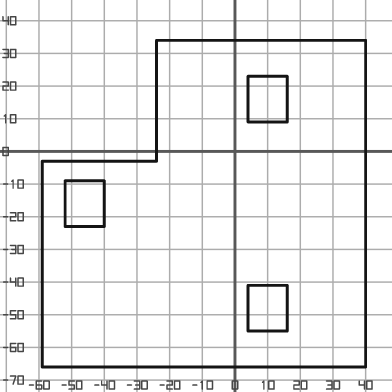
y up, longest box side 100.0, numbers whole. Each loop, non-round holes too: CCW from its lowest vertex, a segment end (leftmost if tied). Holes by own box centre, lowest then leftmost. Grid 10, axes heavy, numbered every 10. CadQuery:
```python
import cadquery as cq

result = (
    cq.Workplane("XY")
    .moveTo(-59.0, -66.0)
    .lineTo(40.0, -66.0)
    .lineTo(40.0, 34.0)
    .lineTo(-24.0, 34.0)
    .lineTo(-24.0, -3.0)
    .lineTo(-59.0, -3.0)
    .close()
    .moveTo(4.0, -55.0)
    .lineTo(16.0, -55.0)
    .lineTo(16.0, -41.0)
    .lineTo(4.0, -41.0)
    .close()
    .moveTo(-52.0, -23.0)
    .lineTo(-40.0, -23.0)
    .lineTo(-40.0, -9.0)
    .lineTo(-52.0, -9.0)
    .close()
    .moveTo(4.0, 9.0)
    .lineTo(16.0, 9.0)
    .lineTo(16.0, 23.0)
    .lineTo(4.0, 23.0)
    .close()
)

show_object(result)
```